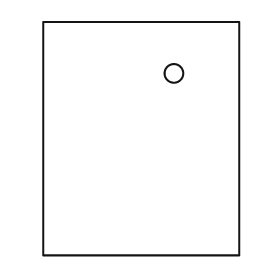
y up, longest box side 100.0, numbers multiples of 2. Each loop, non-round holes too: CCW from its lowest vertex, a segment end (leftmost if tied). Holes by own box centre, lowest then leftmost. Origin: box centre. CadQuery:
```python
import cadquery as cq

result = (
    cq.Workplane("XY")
    .moveTo(-42.0, -50.0)
    .lineTo(42.0, -50.0)
    .lineTo(42.0, 50.0)
    .lineTo(-42.0, 50.0)
    .close()
    .moveTo(14.0, 28.0)
    .circle(4.0)
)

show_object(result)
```